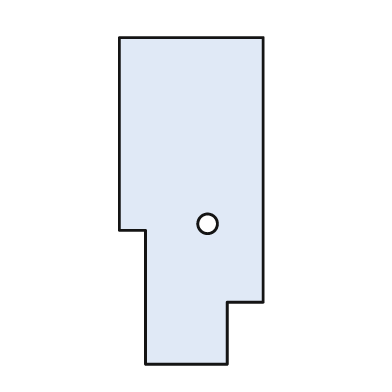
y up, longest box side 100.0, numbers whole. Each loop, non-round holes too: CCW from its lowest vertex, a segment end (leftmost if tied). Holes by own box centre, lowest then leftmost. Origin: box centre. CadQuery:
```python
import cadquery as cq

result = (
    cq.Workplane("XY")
    .moveTo(-14.0, -50.0)
    .lineTo(11.0, -50.0)
    .lineTo(11.0, -31.0)
    .lineTo(22.0, -31.0)
    .lineTo(22.0, 50.0)
    .lineTo(-22.0, 50.0)
    .lineTo(-22.0, -9.0)
    .lineTo(-14.0, -9.0)
    .close()
    .moveTo(5.0, -7.0)
    .circle(3.0)
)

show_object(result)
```